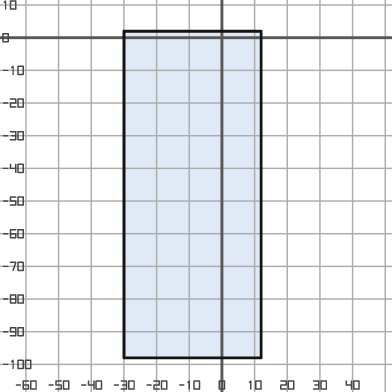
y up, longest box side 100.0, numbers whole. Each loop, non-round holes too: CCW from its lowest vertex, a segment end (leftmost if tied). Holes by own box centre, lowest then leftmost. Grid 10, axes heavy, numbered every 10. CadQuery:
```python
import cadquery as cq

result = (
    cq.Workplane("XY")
    .moveTo(-30.0, -98.0)
    .lineTo(12.0, -98.0)
    .lineTo(12.0, 2.0)
    .lineTo(-30.0, 2.0)
    .close()
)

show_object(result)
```